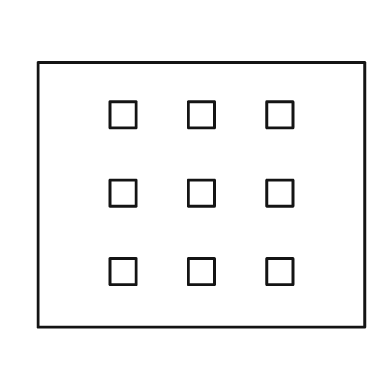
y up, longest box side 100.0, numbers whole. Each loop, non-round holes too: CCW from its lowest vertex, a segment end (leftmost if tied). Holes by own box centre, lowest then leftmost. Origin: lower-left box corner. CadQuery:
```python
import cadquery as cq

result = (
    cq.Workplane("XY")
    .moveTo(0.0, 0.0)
    .lineTo(100.0, 0.0)
    .lineTo(100.0, 81.0)
    .lineTo(0.0, 81.0)
    .close()
    .moveTo(22.0, 13.0)
    .lineTo(30.0, 13.0)
    .lineTo(30.0, 21.0)
    .lineTo(22.0, 21.0)
    .close()
    .moveTo(46.0, 13.0)
    .lineTo(54.0, 13.0)
    .lineTo(54.0, 21.0)
    .lineTo(46.0, 21.0)
    .close()
    .moveTo(70.0, 13.0)
    .lineTo(78.0, 13.0)
    .lineTo(78.0, 21.0)
    .lineTo(70.0, 21.0)
    .close()
    .moveTo(22.0, 37.0)
    .lineTo(30.0, 37.0)
    .lineTo(30.0, 45.0)
    .lineTo(22.0, 45.0)
    .close()
    .moveTo(46.0, 37.0)
    .lineTo(54.0, 37.0)
    .lineTo(54.0, 45.0)
    .lineTo(46.0, 45.0)
    .close()
    .moveTo(70.0, 37.0)
    .lineTo(78.0, 37.0)
    .lineTo(78.0, 45.0)
    .lineTo(70.0, 45.0)
    .close()
    .moveTo(22.0, 61.0)
    .lineTo(30.0, 61.0)
    .lineTo(30.0, 69.0)
    .lineTo(22.0, 69.0)
    .close()
    .moveTo(46.0, 61.0)
    .lineTo(54.0, 61.0)
    .lineTo(54.0, 69.0)
    .lineTo(46.0, 69.0)
    .close()
    .moveTo(70.0, 61.0)
    .lineTo(78.0, 61.0)
    .lineTo(78.0, 69.0)
    .lineTo(70.0, 69.0)
    .close()
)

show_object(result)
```